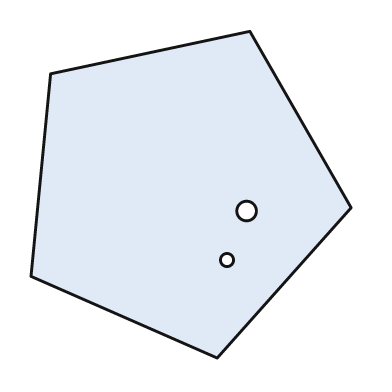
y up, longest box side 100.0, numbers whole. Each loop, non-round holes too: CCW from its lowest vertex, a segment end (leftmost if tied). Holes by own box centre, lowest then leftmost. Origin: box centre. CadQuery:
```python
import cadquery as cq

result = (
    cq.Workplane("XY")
    .moveTo(8.0, -50.0)
    .lineTo(49.0, -4.0)
    .lineTo(18.0, 50.0)
    .lineTo(-43.0, 37.0)
    .lineTo(-49.0, -25.0)
    .close()
    .moveTo(11.0, -20.0)
    .circle(2.0)
    .moveTo(17.0, -5.0)
    .circle(3.0)
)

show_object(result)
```